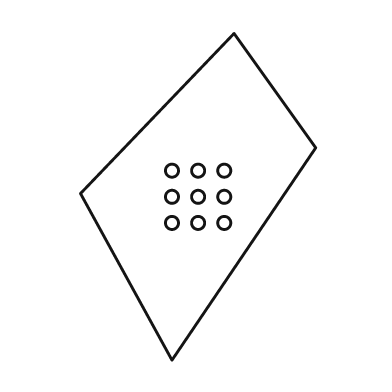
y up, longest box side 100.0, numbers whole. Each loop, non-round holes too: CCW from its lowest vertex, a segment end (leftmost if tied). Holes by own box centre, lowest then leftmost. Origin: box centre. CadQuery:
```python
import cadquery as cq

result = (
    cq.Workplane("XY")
    .moveTo(-8.0, -50.0)
    .lineTo(36.0, 15.0)
    .lineTo(11.0, 50.0)
    .lineTo(-36.0, 1.0)
    .close()
    .moveTo(-8.0, -8.0)
    .circle(2.0)
    .moveTo(0.0, -8.0)
    .circle(2.0)
    .moveTo(8.0, -8.0)
    .circle(2.0)
    .moveTo(-8.0, 0.0)
    .circle(2.0)
    .moveTo(0.0, 0.0)
    .circle(2.0)
    .moveTo(8.0, 0.0)
    .circle(2.0)
    .moveTo(-8.0, 8.0)
    .circle(2.0)
    .moveTo(0.0, 8.0)
    .circle(2.0)
    .moveTo(8.0, 8.0)
    .circle(2.0)
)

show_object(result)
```